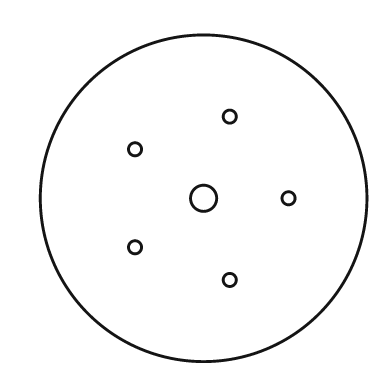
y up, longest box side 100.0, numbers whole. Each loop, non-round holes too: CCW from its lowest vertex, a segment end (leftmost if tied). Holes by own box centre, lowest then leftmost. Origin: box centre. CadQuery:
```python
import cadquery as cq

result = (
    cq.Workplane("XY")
    .moveTo(0.0, 0.0)
    .circle(50.0)
    .moveTo(8.0, -25.0)
    .circle(2.0)
    .moveTo(-21.0, -15.0)
    .circle(2.0)
    .moveTo(0.0, 0.0)
    .circle(4.0)
    .moveTo(26.0, 0.0)
    .circle(2.0)
    .moveTo(-21.0, 15.0)
    .circle(2.0)
    .moveTo(8.0, 25.0)
    .circle(2.0)
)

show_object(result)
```